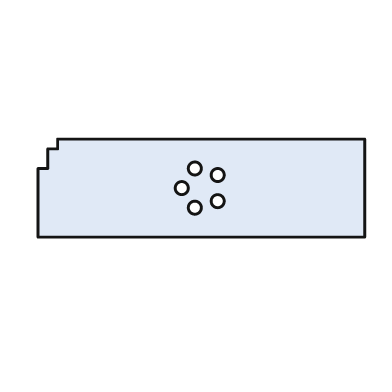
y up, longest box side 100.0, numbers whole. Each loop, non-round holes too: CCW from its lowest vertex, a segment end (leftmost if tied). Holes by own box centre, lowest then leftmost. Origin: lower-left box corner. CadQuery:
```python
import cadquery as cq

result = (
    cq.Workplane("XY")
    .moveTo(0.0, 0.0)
    .lineTo(100.0, 0.0)
    .lineTo(100.0, 30.0)
    .lineTo(6.0, 30.0)
    .lineTo(6.0, 27.0)
    .lineTo(3.0, 27.0)
    .lineTo(3.0, 21.0)
    .lineTo(0.0, 21.0)
    .close()
    .moveTo(48.0, 9.0)
    .circle(2.0)
    .moveTo(55.0, 11.0)
    .circle(2.0)
    .moveTo(44.0, 15.0)
    .circle(2.0)
    .moveTo(55.0, 19.0)
    .circle(2.0)
    .moveTo(48.0, 21.0)
    .circle(2.0)
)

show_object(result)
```